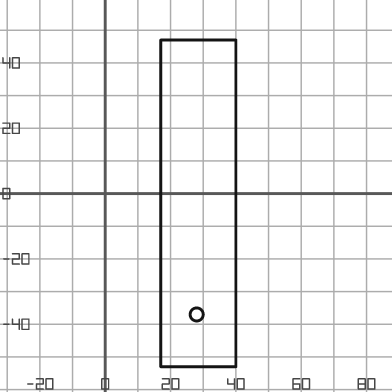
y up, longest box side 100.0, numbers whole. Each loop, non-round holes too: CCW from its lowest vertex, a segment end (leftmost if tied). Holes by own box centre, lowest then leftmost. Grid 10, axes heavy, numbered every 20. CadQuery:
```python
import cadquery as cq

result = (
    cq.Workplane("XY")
    .moveTo(17.0, -53.0)
    .lineTo(40.0, -53.0)
    .lineTo(40.0, 47.0)
    .lineTo(17.0, 47.0)
    .close()
    .moveTo(28.0, -37.0)
    .circle(2.0)
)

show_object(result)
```